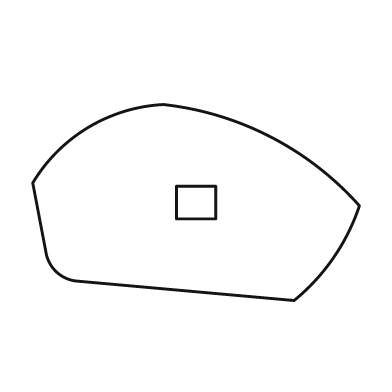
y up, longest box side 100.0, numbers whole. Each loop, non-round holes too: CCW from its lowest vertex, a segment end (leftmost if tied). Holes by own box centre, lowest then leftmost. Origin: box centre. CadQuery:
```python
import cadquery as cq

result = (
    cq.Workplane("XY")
    .moveTo(30.0, -30.0)
    .threePointArc((42.0, -17.0), (50.0, -1.0))
    .threePointArc((23.0, 20.0), (-10.0, 30.0))
    .threePointArc((-33.0, 23.0), (-50.0, 6.0))
    .lineTo(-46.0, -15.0)
    .threePointArc((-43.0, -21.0), (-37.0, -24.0))
    .close()
    .moveTo(-6.0, -5.0)
    .lineTo(6.0, -5.0)
    .lineTo(6.0, 5.0)
    .lineTo(-6.0, 5.0)
    .close()
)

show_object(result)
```